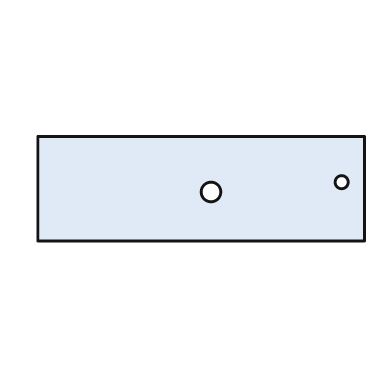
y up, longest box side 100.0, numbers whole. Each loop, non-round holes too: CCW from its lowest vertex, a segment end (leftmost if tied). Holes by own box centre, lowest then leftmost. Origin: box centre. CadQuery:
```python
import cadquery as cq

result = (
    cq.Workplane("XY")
    .moveTo(-50.0, -16.0)
    .lineTo(50.0, -16.0)
    .lineTo(50.0, 16.0)
    .lineTo(-50.0, 16.0)
    .close()
    .moveTo(3.0, -1.0)
    .circle(3.0)
    .moveTo(43.0, 2.0)
    .circle(2.0)
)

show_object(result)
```